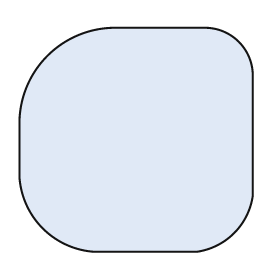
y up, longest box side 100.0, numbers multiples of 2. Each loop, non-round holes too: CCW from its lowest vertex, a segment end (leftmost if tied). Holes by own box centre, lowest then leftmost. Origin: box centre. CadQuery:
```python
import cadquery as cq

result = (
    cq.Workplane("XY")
    .moveTo(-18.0, -48.0)
    .lineTo(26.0, -48.0)
    .threePointArc((42.0, -40.0), (50.0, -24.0))
    .lineTo(50.0, 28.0)
    .threePointArc((44.0, 42.0), (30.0, 48.0))
    .lineTo(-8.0, 48.0)
    .threePointArc((-38.0, 36.0), (-50.0, 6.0))
    .lineTo(-50.0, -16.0)
    .threePointArc((-40.0, -38.0), (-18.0, -48.0))
    .close()
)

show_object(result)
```